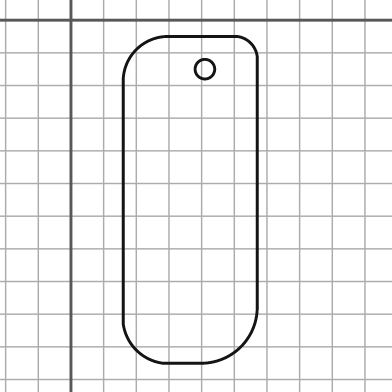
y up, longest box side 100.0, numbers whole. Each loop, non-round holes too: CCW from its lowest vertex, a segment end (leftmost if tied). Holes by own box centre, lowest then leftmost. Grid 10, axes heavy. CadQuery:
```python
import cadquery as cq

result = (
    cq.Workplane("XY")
    .moveTo(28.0, -105.0)
    .lineTo(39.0, -105.0)
    .threePointArc((52.0, -100.0), (57.0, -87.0))
    .lineTo(57.0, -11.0)
    .threePointArc((55.0, -7.0), (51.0, -5.0))
    .lineTo(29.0, -5.0)
    .threePointArc((20.0, -9.0), (16.0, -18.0))
    .lineTo(16.0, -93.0)
    .threePointArc((20.0, -101.0), (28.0, -105.0))
    .close()
    .moveTo(41.0, -15.0)
    .circle(3.0)
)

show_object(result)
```